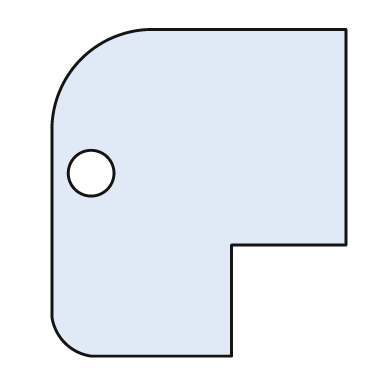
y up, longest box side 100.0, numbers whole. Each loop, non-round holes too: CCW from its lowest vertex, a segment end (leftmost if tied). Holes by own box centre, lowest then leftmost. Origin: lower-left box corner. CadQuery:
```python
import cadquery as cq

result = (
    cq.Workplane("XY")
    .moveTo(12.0, 0.0)
    .lineTo(55.0, 0.0)
    .lineTo(55.0, 34.0)
    .lineTo(90.0, 34.0)
    .lineTo(90.0, 100.0)
    .lineTo(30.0, 100.0)
    .threePointArc((9.0, 91.0), (0.0, 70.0))
    .lineTo(0.0, 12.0)
    .threePointArc((4.0, 4.0), (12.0, 0.0))
    .close()
    .moveTo(12.0, 56.0)
    .circle(7.0)
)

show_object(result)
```